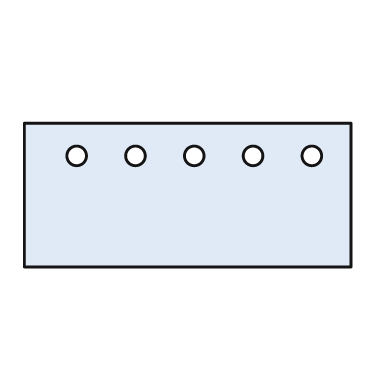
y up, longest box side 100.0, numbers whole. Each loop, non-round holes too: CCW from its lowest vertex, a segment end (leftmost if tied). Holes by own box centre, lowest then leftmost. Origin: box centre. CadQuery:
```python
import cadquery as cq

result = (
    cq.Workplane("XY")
    .moveTo(-50.0, -22.0)
    .lineTo(50.0, -22.0)
    .lineTo(50.0, 22.0)
    .lineTo(-50.0, 22.0)
    .close()
    .moveTo(-34.0, 12.0)
    .circle(3.0)
    .moveTo(-16.0, 12.0)
    .circle(3.0)
    .moveTo(2.0, 12.0)
    .circle(3.0)
    .moveTo(20.0, 12.0)
    .circle(3.0)
    .moveTo(38.0, 12.0)
    .circle(3.0)
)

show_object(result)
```